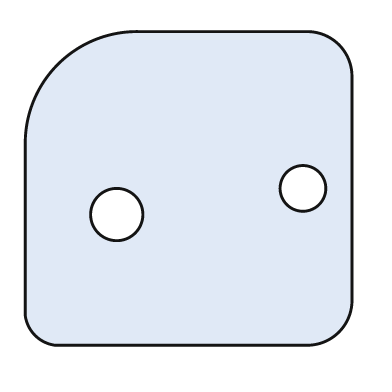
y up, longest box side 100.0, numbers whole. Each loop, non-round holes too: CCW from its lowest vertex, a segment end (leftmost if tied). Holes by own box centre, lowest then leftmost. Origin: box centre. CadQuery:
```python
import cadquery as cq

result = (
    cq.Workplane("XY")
    .moveTo(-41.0, -48.0)
    .lineTo(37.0, -48.0)
    .threePointArc((46.0, -44.0), (50.0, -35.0))
    .lineTo(50.0, 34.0)
    .threePointArc((46.0, 44.0), (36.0, 48.0))
    .lineTo(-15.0, 48.0)
    .threePointArc((-40.0, 38.0), (-50.0, 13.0))
    .lineTo(-50.0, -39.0)
    .threePointArc((-47.0, -45.0), (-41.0, -48.0))
    .close()
    .moveTo(-22.0, -8.0)
    .circle(8.0)
    .moveTo(35.0, 0.0)
    .circle(7.0)
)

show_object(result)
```